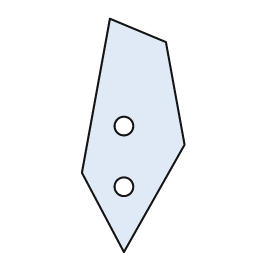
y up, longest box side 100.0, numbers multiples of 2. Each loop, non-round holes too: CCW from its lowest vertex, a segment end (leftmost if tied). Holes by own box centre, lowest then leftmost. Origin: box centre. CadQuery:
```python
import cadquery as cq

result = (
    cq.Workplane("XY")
    .moveTo(-4.0, -50.0)
    .lineTo(22.0, -4.0)
    .lineTo(14.0, 40.0)
    .lineTo(-10.0, 50.0)
    .lineTo(-22.0, -16.0)
    .close()
    .moveTo(-4.0, -22.0)
    .circle(4.0)
    .moveTo(-4.0, 4.0)
    .circle(4.0)
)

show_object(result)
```